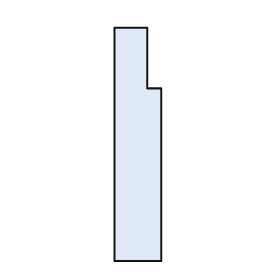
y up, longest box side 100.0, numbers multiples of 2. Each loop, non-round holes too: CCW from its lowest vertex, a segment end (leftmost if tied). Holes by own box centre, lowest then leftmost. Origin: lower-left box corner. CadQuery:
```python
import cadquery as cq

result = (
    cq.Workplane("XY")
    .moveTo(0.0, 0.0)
    .lineTo(20.0, 0.0)
    .lineTo(20.0, 74.0)
    .lineTo(14.0, 74.0)
    .lineTo(14.0, 100.0)
    .lineTo(0.0, 100.0)
    .close()
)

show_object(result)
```